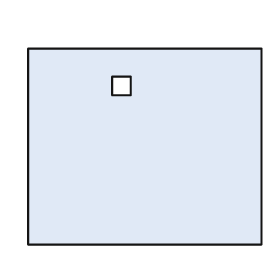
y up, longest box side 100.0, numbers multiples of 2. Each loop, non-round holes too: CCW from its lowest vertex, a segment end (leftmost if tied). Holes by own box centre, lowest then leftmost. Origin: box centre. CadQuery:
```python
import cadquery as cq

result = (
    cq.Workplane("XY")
    .moveTo(-50.0, -42.0)
    .lineTo(50.0, -42.0)
    .lineTo(50.0, 42.0)
    .lineTo(-50.0, 42.0)
    .close()
    .moveTo(-14.0, 22.0)
    .lineTo(-6.0, 22.0)
    .lineTo(-6.0, 30.0)
    .lineTo(-14.0, 30.0)
    .close()
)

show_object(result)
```